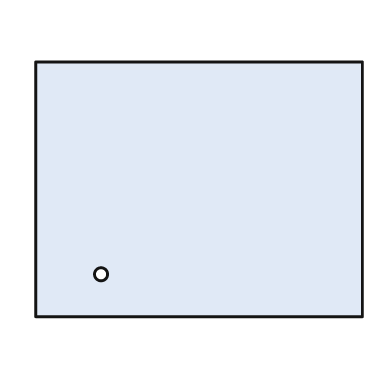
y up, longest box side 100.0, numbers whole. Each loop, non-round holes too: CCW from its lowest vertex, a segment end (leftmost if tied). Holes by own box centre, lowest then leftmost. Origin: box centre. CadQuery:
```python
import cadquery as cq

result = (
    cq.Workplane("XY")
    .moveTo(-50.0, -39.0)
    .lineTo(50.0, -39.0)
    .lineTo(50.0, 39.0)
    .lineTo(-50.0, 39.0)
    .close()
    .moveTo(-30.0, -26.0)
    .circle(2.0)
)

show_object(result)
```